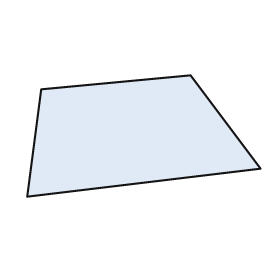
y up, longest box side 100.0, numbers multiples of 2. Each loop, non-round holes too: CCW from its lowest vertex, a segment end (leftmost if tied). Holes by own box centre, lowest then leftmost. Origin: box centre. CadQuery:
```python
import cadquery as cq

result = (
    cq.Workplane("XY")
    .moveTo(-50.0, -26.0)
    .lineTo(50.0, -14.0)
    .lineTo(20.0, 26.0)
    .lineTo(-44.0, 20.0)
    .close()
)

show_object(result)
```